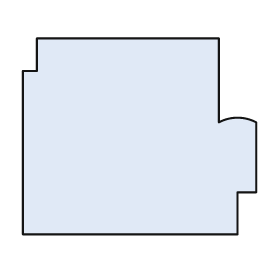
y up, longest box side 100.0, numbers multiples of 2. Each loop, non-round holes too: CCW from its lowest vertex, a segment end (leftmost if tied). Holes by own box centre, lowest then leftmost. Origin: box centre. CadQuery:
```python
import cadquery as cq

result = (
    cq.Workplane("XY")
    .moveTo(-50.0, -42.0)
    .lineTo(42.0, -42.0)
    .lineTo(42.0, -24.0)
    .lineTo(50.0, -24.0)
    .lineTo(50.0, 6.0)
    .threePointArc((42.0, 8.0), (34.0, 6.0))
    .lineTo(34.0, 42.0)
    .lineTo(-44.0, 42.0)
    .lineTo(-44.0, 28.0)
    .lineTo(-50.0, 28.0)
    .close()
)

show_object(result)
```